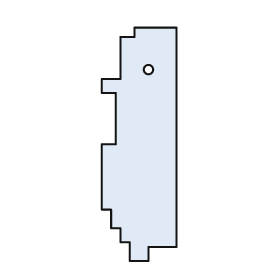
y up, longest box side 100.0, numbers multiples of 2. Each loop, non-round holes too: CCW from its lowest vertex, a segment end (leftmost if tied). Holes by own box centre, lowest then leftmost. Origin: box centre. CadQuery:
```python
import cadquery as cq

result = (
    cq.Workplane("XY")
    .moveTo(-4.0, -50.0)
    .lineTo(4.0, -50.0)
    .lineTo(4.0, -44.0)
    .lineTo(16.0, -44.0)
    .lineTo(16.0, 50.0)
    .lineTo(-2.0, 50.0)
    .lineTo(-2.0, 46.0)
    .lineTo(-8.0, 46.0)
    .lineTo(-8.0, 28.0)
    .lineTo(-16.0, 28.0)
    .lineTo(-16.0, 22.0)
    .lineTo(-10.0, 22.0)
    .lineTo(-10.0, 0.0)
    .lineTo(-16.0, 0.0)
    .lineTo(-16.0, -28.0)
    .lineTo(-12.0, -28.0)
    .lineTo(-12.0, -36.0)
    .lineTo(-8.0, -36.0)
    .lineTo(-8.0, -42.0)
    .lineTo(-4.0, -42.0)
    .close()
    .moveTo(4.0, 32.0)
    .circle(2.0)
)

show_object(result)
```